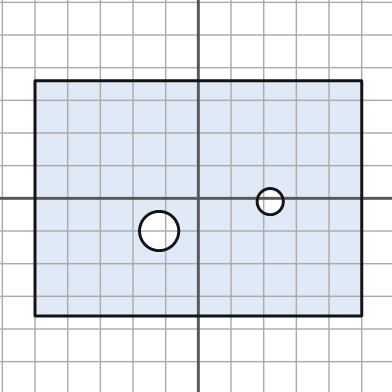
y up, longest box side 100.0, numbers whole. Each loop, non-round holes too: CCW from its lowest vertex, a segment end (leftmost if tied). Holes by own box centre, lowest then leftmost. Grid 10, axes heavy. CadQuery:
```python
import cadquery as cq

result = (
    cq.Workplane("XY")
    .moveTo(-50.0, -36.0)
    .lineTo(50.0, -36.0)
    .lineTo(50.0, 36.0)
    .lineTo(-50.0, 36.0)
    .close()
    .moveTo(-12.0, -10.0)
    .circle(6.0)
    .moveTo(22.0, -1.0)
    .circle(4.0)
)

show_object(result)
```